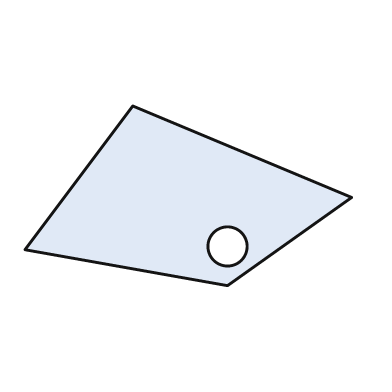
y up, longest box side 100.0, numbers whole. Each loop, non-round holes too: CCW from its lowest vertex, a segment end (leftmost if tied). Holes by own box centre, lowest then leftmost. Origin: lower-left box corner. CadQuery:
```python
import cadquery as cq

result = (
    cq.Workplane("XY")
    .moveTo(62.0, 0.0)
    .lineTo(100.0, 27.0)
    .lineTo(33.0, 55.0)
    .lineTo(0.0, 11.0)
    .close()
    .moveTo(62.0, 12.0)
    .circle(6.0)
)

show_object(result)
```